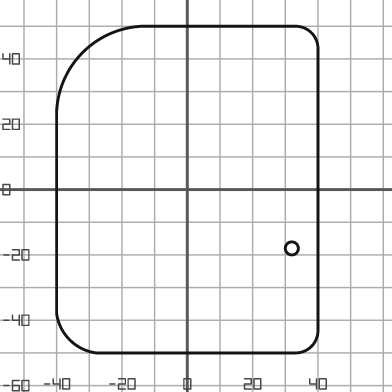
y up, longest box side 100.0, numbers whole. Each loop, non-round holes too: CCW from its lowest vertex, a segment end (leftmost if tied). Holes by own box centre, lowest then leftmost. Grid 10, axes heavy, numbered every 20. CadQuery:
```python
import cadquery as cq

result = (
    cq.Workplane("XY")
    .moveTo(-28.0, -50.0)
    .lineTo(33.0, -50.0)
    .threePointArc((38.0, -48.0), (40.0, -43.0))
    .lineTo(40.0, 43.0)
    .threePointArc((38.0, 48.0), (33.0, 50.0))
    .lineTo(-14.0, 50.0)
    .threePointArc((-32.0, 42.0), (-40.0, 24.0))
    .lineTo(-40.0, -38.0)
    .threePointArc((-36.0, -46.0), (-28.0, -50.0))
    .close()
    .moveTo(32.0, -18.0)
    .circle(2.0)
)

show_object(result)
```